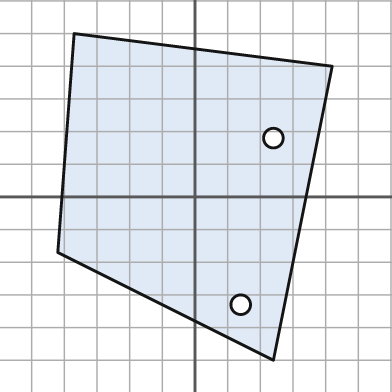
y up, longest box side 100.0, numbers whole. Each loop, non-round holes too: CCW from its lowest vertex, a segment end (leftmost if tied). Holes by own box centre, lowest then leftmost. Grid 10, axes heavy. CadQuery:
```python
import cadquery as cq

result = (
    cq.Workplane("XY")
    .moveTo(24.0, -50.0)
    .lineTo(42.0, 40.0)
    .lineTo(-37.0, 50.0)
    .lineTo(-42.0, -17.0)
    .close()
    .moveTo(14.0, -33.0)
    .circle(3.0)
    .moveTo(24.0, 18.0)
    .circle(3.0)
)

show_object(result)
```